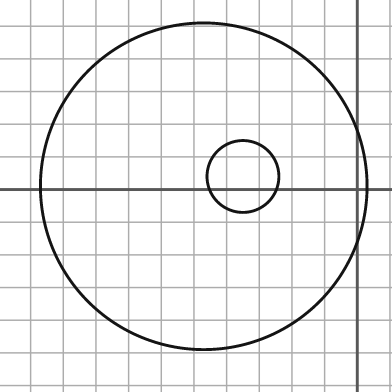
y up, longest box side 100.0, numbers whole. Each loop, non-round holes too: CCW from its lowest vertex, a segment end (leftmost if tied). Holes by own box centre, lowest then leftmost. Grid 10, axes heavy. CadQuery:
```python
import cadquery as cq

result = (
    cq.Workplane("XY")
    .moveTo(-47.0, 1.0)
    .circle(50.0)
    .moveTo(-35.0, 4.0)
    .circle(11.0)
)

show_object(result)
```